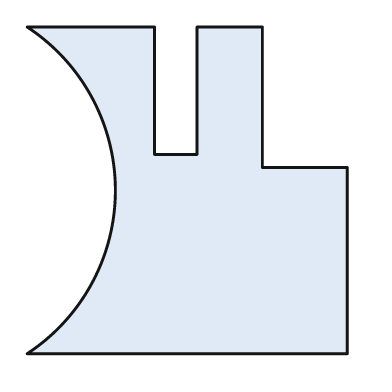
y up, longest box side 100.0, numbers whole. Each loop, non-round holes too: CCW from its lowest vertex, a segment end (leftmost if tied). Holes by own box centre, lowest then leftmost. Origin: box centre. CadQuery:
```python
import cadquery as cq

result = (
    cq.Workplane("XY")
    .moveTo(-49.0, -50.0)
    .lineTo(49.0, -50.0)
    .lineTo(49.0, 7.0)
    .lineTo(23.0, 7.0)
    .lineTo(23.0, 50.0)
    .lineTo(3.0, 50.0)
    .lineTo(3.0, 11.0)
    .lineTo(-10.0, 11.0)
    .lineTo(-10.0, 50.0)
    .lineTo(-49.0, 50.0)
    .threePointArc((-22.0, 0.0), (-49.0, -50.0))
    .close()
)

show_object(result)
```